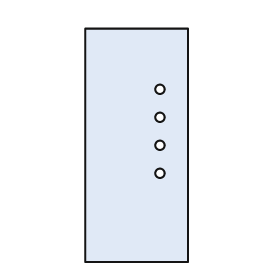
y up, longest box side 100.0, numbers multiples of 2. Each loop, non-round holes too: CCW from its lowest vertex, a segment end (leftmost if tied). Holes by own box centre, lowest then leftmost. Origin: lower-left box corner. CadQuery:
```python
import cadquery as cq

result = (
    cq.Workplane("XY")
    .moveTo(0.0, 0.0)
    .lineTo(44.0, 0.0)
    .lineTo(44.0, 100.0)
    .lineTo(0.0, 100.0)
    .close()
    .moveTo(32.0, 38.0)
    .circle(2.0)
    .moveTo(32.0, 50.0)
    .circle(2.0)
    .moveTo(32.0, 62.0)
    .circle(2.0)
    .moveTo(32.0, 74.0)
    .circle(2.0)
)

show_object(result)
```